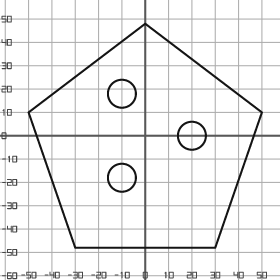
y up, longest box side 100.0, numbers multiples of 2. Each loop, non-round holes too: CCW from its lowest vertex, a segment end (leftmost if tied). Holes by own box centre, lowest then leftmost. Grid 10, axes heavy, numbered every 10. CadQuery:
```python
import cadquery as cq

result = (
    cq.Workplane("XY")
    .moveTo(-30.0, -48.0)
    .lineTo(30.0, -48.0)
    .lineTo(50.0, 10.0)
    .lineTo(0.0, 48.0)
    .lineTo(-50.0, 10.0)
    .close()
    .moveTo(-10.0, -18.0)
    .circle(6.0)
    .moveTo(20.0, 0.0)
    .circle(6.0)
    .moveTo(-10.0, 18.0)
    .circle(6.0)
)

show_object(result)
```